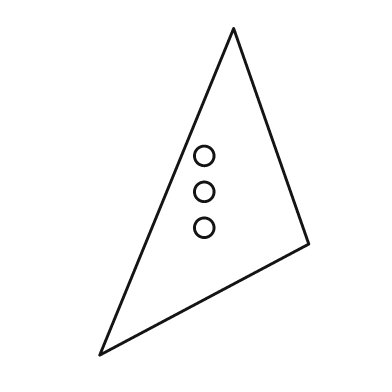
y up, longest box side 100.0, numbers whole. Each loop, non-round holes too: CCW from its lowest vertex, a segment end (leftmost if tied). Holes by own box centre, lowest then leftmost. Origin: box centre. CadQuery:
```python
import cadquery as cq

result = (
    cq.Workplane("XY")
    .moveTo(-32.0, -50.0)
    .lineTo(32.0, -16.0)
    .lineTo(9.0, 50.0)
    .close()
    .moveTo(0.0, -11.0)
    .circle(3.0)
    .moveTo(0.0, 0.0)
    .circle(3.0)
    .moveTo(0.0, 11.0)
    .circle(3.0)
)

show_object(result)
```